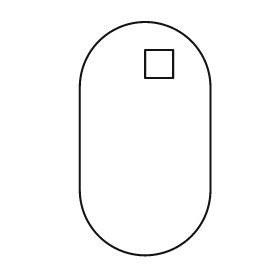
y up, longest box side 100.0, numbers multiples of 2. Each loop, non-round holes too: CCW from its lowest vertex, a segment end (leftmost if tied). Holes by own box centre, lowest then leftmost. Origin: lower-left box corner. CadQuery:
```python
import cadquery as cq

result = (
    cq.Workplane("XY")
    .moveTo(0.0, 28.0)
    .threePointArc((28.0, 0.0), (56.0, 28.0))
    .lineTo(56.0, 72.0)
    .threePointArc((28.0, 100.0), (0.0, 72.0))
    .close()
    .moveTo(28.0, 76.0)
    .lineTo(40.0, 76.0)
    .lineTo(40.0, 88.0)
    .lineTo(28.0, 88.0)
    .close()
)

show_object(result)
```